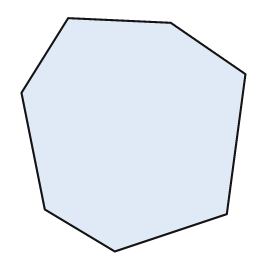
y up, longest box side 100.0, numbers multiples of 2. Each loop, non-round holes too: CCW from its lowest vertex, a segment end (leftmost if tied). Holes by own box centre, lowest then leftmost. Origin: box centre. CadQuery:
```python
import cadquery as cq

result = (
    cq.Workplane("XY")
    .moveTo(-8.0, -50.0)
    .lineTo(40.0, -34.0)
    .lineTo(48.0, 26.0)
    .lineTo(16.0, 48.0)
    .lineTo(-28.0, 50.0)
    .lineTo(-48.0, 18.0)
    .lineTo(-38.0, -32.0)
    .close()
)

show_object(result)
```